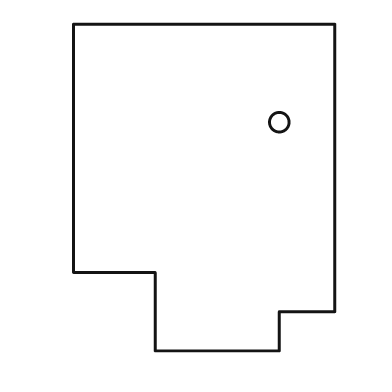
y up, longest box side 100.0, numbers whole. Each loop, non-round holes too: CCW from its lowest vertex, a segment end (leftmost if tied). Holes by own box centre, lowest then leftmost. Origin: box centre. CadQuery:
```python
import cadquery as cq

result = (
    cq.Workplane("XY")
    .moveTo(-15.0, -50.0)
    .lineTo(23.0, -50.0)
    .lineTo(23.0, -38.0)
    .lineTo(40.0, -38.0)
    .lineTo(40.0, 50.0)
    .lineTo(-40.0, 50.0)
    .lineTo(-40.0, -26.0)
    .lineTo(-15.0, -26.0)
    .close()
    .moveTo(23.0, 20.0)
    .circle(3.0)
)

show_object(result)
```